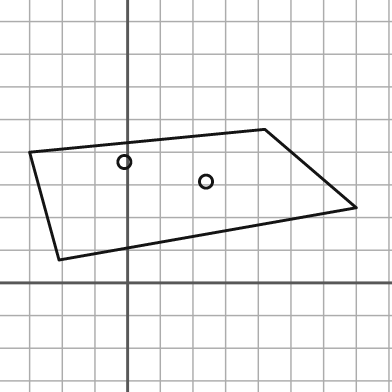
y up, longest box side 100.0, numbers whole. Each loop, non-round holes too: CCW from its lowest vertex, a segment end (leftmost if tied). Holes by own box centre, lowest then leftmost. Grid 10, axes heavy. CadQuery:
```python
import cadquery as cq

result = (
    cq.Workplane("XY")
    .moveTo(-21.0, 7.0)
    .lineTo(70.0, 23.0)
    .lineTo(42.0, 47.0)
    .lineTo(-30.0, 40.0)
    .close()
    .moveTo(24.0, 31.0)
    .circle(2.0)
    .moveTo(-1.0, 37.0)
    .circle(2.0)
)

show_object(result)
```